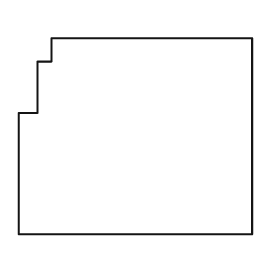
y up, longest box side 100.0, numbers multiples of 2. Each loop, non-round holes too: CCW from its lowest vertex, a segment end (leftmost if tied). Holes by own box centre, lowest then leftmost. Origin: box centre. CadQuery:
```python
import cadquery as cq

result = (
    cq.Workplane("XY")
    .moveTo(-50.0, -42.0)
    .lineTo(50.0, -42.0)
    .lineTo(50.0, 42.0)
    .lineTo(-36.0, 42.0)
    .lineTo(-36.0, 32.0)
    .lineTo(-42.0, 32.0)
    .lineTo(-42.0, 10.0)
    .lineTo(-50.0, 10.0)
    .close()
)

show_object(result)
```